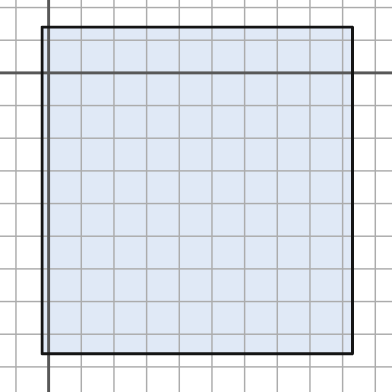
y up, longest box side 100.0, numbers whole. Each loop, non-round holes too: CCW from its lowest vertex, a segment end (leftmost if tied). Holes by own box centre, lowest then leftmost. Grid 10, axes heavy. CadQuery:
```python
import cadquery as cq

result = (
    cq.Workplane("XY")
    .moveTo(-2.0, -86.0)
    .lineTo(93.0, -86.0)
    .lineTo(93.0, 14.0)
    .lineTo(-2.0, 14.0)
    .close()
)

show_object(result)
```